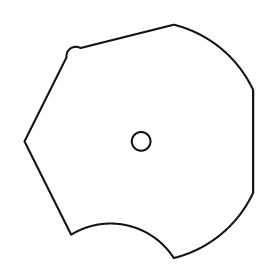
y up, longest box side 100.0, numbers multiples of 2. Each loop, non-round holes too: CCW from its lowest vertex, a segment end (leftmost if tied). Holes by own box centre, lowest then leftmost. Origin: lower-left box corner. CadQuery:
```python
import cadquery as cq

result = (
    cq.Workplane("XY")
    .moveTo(64.0, 0.0)
    .threePointArc((84.0, 10.0), (98.0, 28.0))
    .lineTo(98.0, 72.0)
    .threePointArc((84.0, 90.0), (64.0, 100.0))
    .lineTo(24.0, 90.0)
    .threePointArc((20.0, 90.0), (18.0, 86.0))
    .lineTo(0.0, 50.0)
    .lineTo(20.0, 10.0)
    .threePointArc((44.0, 14.0), (64.0, 0.0))
    .close()
    .moveTo(50.0, 50.0)
    .circle(4.0)
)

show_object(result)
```